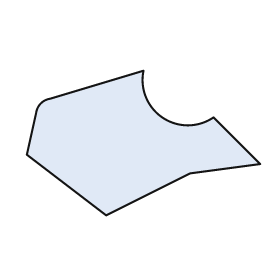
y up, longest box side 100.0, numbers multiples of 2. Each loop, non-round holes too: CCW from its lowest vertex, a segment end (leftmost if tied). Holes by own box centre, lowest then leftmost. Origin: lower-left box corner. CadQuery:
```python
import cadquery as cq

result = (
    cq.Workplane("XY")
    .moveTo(34.0, 0.0)
    .lineTo(70.0, 18.0)
    .lineTo(100.0, 22.0)
    .lineTo(80.0, 42.0)
    .threePointArc((58.0, 42.0), (50.0, 62.0))
    .lineTo(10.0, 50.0)
    .threePointArc((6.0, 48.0), (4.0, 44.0))
    .lineTo(0.0, 26.0)
    .close()
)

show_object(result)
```